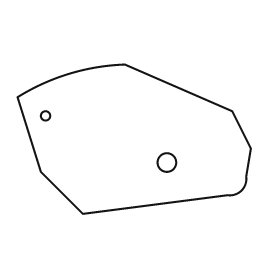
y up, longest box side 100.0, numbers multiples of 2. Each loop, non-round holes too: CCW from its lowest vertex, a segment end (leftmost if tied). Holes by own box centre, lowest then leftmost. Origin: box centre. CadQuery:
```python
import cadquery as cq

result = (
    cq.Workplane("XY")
    .moveTo(-22.0, -32.0)
    .lineTo(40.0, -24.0)
    .threePointArc((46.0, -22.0), (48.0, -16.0))
    .lineTo(50.0, -4.0)
    .lineTo(42.0, 12.0)
    .lineTo(-4.0, 32.0)
    .threePointArc((-28.0, 28.0), (-50.0, 18.0))
    .lineTo(-40.0, -14.0)
    .close()
    .moveTo(14.0, -10.0)
    .circle(4.0)
    .moveTo(-38.0, 10.0)
    .circle(2.0)
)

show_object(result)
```